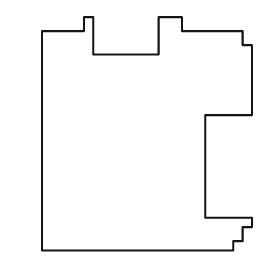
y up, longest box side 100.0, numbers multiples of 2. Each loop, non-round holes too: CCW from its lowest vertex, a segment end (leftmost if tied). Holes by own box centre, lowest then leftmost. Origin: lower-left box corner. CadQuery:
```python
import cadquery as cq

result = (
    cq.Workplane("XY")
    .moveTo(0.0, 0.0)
    .lineTo(82.0, 0.0)
    .lineTo(82.0, 4.0)
    .lineTo(86.0, 4.0)
    .lineTo(86.0, 10.0)
    .lineTo(90.0, 10.0)
    .lineTo(90.0, 14.0)
    .lineTo(70.0, 14.0)
    .lineTo(70.0, 58.0)
    .lineTo(90.0, 58.0)
    .lineTo(90.0, 88.0)
    .lineTo(86.0, 88.0)
    .lineTo(86.0, 94.0)
    .lineTo(60.0, 94.0)
    .lineTo(60.0, 100.0)
    .lineTo(50.0, 100.0)
    .lineTo(50.0, 84.0)
    .lineTo(22.0, 84.0)
    .lineTo(22.0, 100.0)
    .lineTo(18.0, 100.0)
    .lineTo(18.0, 94.0)
    .lineTo(0.0, 94.0)
    .close()
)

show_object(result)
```